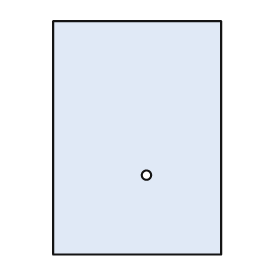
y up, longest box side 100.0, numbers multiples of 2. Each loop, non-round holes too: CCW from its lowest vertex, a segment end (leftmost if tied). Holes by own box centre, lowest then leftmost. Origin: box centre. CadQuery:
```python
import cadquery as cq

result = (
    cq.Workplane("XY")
    .moveTo(-36.0, -50.0)
    .lineTo(36.0, -50.0)
    .lineTo(36.0, 50.0)
    .lineTo(-36.0, 50.0)
    .close()
    .moveTo(4.0, -16.0)
    .circle(2.0)
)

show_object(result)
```